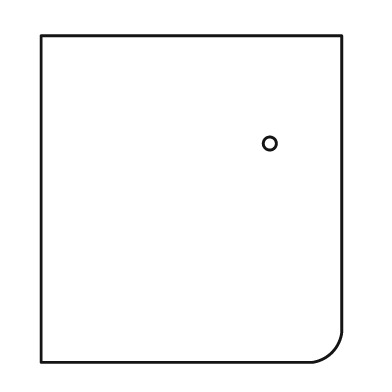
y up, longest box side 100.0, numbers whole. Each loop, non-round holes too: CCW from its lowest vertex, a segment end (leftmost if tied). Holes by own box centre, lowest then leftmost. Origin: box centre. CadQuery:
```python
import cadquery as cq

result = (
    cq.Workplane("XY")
    .moveTo(-46.0, -50.0)
    .lineTo(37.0, -50.0)
    .threePointArc((43.0, -47.0), (46.0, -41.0))
    .lineTo(46.0, 50.0)
    .lineTo(-46.0, 50.0)
    .close()
    .moveTo(24.0, 17.0)
    .circle(2.0)
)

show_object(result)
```